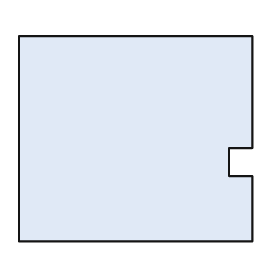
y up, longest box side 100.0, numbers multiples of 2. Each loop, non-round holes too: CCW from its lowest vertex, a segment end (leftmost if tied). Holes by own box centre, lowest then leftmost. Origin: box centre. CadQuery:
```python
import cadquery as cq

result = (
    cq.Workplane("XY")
    .moveTo(-50.0, -44.0)
    .lineTo(50.0, -44.0)
    .lineTo(50.0, -16.0)
    .lineTo(40.0, -16.0)
    .lineTo(40.0, -4.0)
    .lineTo(50.0, -4.0)
    .lineTo(50.0, 44.0)
    .lineTo(-50.0, 44.0)
    .close()
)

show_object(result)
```